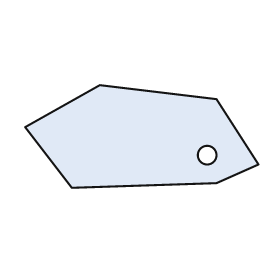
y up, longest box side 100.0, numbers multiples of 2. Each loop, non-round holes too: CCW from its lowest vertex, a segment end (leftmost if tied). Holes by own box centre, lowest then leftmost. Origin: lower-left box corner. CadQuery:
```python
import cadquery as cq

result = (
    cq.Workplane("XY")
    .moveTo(20.0, 0.0)
    .lineTo(82.0, 2.0)
    .lineTo(100.0, 10.0)
    .lineTo(82.0, 38.0)
    .lineTo(32.0, 44.0)
    .lineTo(0.0, 26.0)
    .close()
    .moveTo(78.0, 14.0)
    .circle(4.0)
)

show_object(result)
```